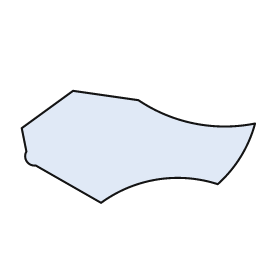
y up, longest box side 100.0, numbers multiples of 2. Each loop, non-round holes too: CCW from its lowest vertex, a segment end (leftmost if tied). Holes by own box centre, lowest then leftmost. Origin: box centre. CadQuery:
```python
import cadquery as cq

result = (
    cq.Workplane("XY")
    .moveTo(-16.0, -24.0)
    .threePointArc((8.0, -14.0), (34.0, -16.0))
    .threePointArc((44.0, -4.0), (50.0, 10.0))
    .threePointArc((24.0, 10.0), (0.0, 20.0))
    .lineTo(-28.0, 24.0)
    .lineTo(-50.0, 8.0)
    .lineTo(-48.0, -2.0)
    .threePointArc((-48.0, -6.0), (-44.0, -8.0))
    .close()
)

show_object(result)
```